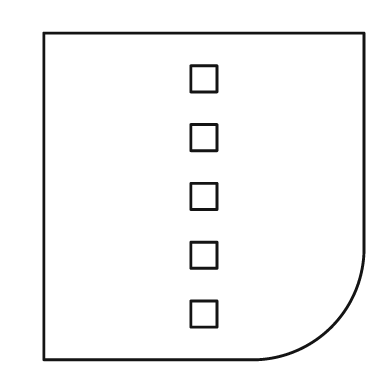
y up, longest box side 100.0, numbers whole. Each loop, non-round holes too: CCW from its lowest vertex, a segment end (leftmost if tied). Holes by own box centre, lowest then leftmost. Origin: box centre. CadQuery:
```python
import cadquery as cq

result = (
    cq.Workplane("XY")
    .moveTo(-49.0, -50.0)
    .lineTo(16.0, -50.0)
    .threePointArc((39.0, -40.0), (49.0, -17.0))
    .lineTo(49.0, 50.0)
    .lineTo(-49.0, 50.0)
    .close()
    .moveTo(-4.0, -40.0)
    .lineTo(4.0, -40.0)
    .lineTo(4.0, -32.0)
    .lineTo(-4.0, -32.0)
    .close()
    .moveTo(-4.0, -22.0)
    .lineTo(4.0, -22.0)
    .lineTo(4.0, -14.0)
    .lineTo(-4.0, -14.0)
    .close()
    .moveTo(-4.0, -4.0)
    .lineTo(4.0, -4.0)
    .lineTo(4.0, 4.0)
    .lineTo(-4.0, 4.0)
    .close()
    .moveTo(-4.0, 14.0)
    .lineTo(4.0, 14.0)
    .lineTo(4.0, 22.0)
    .lineTo(-4.0, 22.0)
    .close()
    .moveTo(-4.0, 32.0)
    .lineTo(4.0, 32.0)
    .lineTo(4.0, 40.0)
    .lineTo(-4.0, 40.0)
    .close()
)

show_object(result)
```